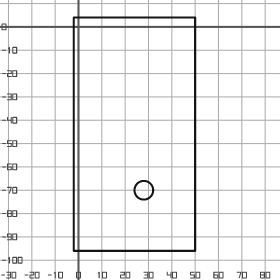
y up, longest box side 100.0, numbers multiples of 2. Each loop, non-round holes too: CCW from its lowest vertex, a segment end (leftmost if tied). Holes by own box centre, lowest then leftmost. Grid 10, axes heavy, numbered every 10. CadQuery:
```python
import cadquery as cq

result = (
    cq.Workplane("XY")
    .moveTo(-2.0, -96.0)
    .lineTo(50.0, -96.0)
    .lineTo(50.0, 4.0)
    .lineTo(-2.0, 4.0)
    .close()
    .moveTo(28.0, -70.0)
    .circle(4.0)
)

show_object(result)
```